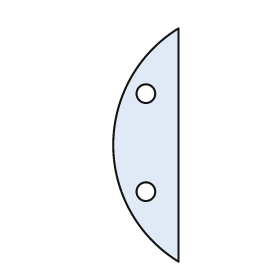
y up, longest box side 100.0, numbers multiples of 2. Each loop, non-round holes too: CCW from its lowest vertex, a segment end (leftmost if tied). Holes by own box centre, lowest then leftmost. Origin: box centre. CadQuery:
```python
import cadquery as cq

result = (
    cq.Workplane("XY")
    .moveTo(14.0, -50.0)
    .lineTo(14.0, 50.0)
    .threePointArc((-14.0, 0.0), (14.0, -50.0))
    .close()
    .moveTo(0.0, -20.0)
    .circle(4.0)
    .moveTo(0.0, 22.0)
    .circle(4.0)
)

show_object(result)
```